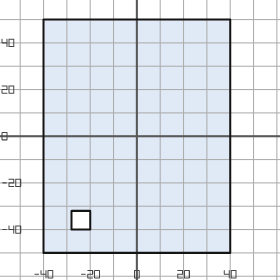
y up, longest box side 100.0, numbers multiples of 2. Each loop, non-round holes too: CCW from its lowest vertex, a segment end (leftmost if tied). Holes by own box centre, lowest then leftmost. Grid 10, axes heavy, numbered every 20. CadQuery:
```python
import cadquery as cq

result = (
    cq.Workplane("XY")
    .moveTo(-40.0, -50.0)
    .lineTo(40.0, -50.0)
    .lineTo(40.0, 50.0)
    .lineTo(-40.0, 50.0)
    .close()
    .moveTo(-28.0, -40.0)
    .lineTo(-20.0, -40.0)
    .lineTo(-20.0, -32.0)
    .lineTo(-28.0, -32.0)
    .close()
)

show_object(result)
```